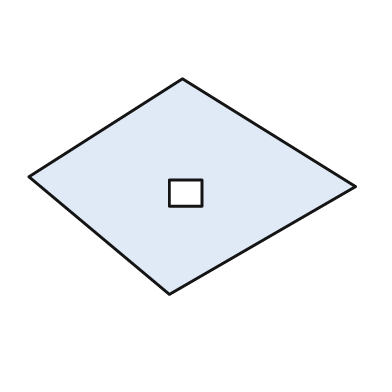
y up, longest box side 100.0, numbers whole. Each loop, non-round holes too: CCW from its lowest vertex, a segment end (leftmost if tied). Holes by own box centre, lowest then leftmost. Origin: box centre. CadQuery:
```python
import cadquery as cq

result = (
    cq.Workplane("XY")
    .moveTo(-7.0, -33.0)
    .lineTo(50.0, 0.0)
    .lineTo(-3.0, 33.0)
    .lineTo(-50.0, 3.0)
    .close()
    .moveTo(-7.0, -6.0)
    .lineTo(3.0, -6.0)
    .lineTo(3.0, 2.0)
    .lineTo(-7.0, 2.0)
    .close()
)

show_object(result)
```